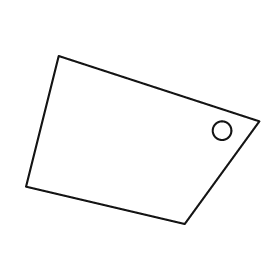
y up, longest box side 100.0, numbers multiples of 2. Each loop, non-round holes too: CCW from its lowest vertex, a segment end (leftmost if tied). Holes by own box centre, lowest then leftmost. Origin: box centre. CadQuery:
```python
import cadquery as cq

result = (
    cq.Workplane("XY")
    .moveTo(18.0, -36.0)
    .lineTo(50.0, 8.0)
    .lineTo(-36.0, 36.0)
    .lineTo(-50.0, -20.0)
    .close()
    .moveTo(34.0, 4.0)
    .circle(4.0)
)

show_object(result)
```